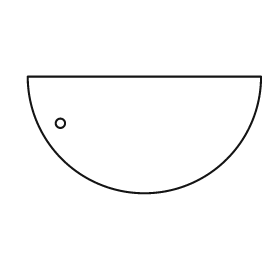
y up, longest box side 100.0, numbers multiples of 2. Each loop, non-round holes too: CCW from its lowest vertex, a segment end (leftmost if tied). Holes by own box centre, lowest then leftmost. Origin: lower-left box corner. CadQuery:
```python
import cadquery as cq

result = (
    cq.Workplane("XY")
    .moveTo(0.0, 50.0)
    .threePointArc((50.0, 0.0), (100.0, 50.0))
    .close()
    .moveTo(14.0, 30.0)
    .circle(2.0)
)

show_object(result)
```